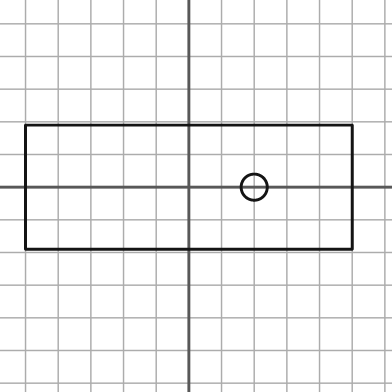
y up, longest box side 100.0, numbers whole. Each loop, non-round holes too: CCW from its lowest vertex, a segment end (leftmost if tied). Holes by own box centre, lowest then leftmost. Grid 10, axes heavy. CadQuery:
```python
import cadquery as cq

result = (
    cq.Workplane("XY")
    .moveTo(-50.0, -19.0)
    .lineTo(50.0, -19.0)
    .lineTo(50.0, 19.0)
    .lineTo(-50.0, 19.0)
    .close()
    .moveTo(20.0, 0.0)
    .circle(4.0)
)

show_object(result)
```